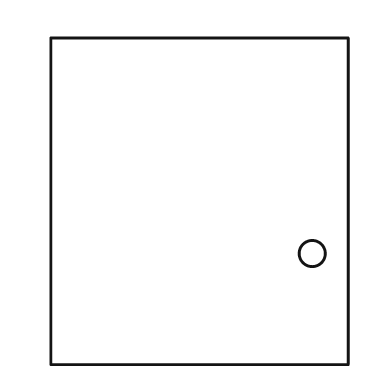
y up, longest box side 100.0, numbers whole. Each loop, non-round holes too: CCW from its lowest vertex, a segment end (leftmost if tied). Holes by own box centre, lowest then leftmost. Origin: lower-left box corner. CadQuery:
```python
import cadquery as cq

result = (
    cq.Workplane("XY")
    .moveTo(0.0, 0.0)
    .lineTo(91.0, 0.0)
    .lineTo(91.0, 100.0)
    .lineTo(0.0, 100.0)
    .close()
    .moveTo(80.0, 34.0)
    .circle(4.0)
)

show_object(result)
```